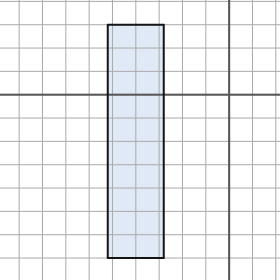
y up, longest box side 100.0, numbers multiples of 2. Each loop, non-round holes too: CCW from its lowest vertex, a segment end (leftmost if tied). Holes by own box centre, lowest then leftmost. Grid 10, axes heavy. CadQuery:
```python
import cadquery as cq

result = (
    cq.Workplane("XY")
    .moveTo(-52.0, -70.0)
    .lineTo(-28.0, -70.0)
    .lineTo(-28.0, 30.0)
    .lineTo(-52.0, 30.0)
    .close()
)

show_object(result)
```